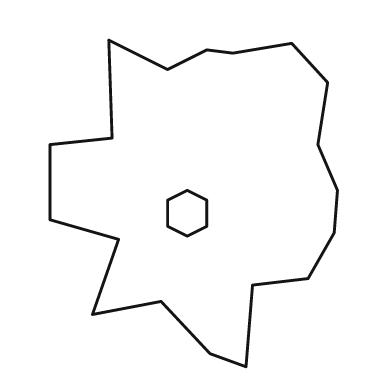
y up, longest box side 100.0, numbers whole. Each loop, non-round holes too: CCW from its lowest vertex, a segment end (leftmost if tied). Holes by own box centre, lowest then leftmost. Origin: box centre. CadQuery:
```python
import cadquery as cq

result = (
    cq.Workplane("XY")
    .moveTo(16.0, -50.0)
    .lineTo(18.0, -25.0)
    .lineTo(35.0, -23.0)
    .lineTo(43.0, -9.0)
    .lineTo(44.0, 4.0)
    .lineTo(38.0, 18.0)
    .lineTo(41.0, 37.0)
    .lineTo(30.0, 49.0)
    .lineTo(12.0, 46.0)
    .lineTo(4.0, 47.0)
    .lineTo(-8.0, 41.0)
    .lineTo(-26.0, 50.0)
    .lineTo(-25.0, 20.0)
    .lineTo(-44.0, 18.0)
    .lineTo(-44.0, -5.0)
    .lineTo(-23.0, -11.0)
    .lineTo(-31.0, -34.0)
    .lineTo(-10.0, -30.0)
    .lineTo(5.0, -46.0)
    .close()
    .moveTo(-2.0, -10.0)
    .lineTo(4.0, -7.0)
    .lineTo(4.0, 1.0)
    .lineTo(-2.0, 4.0)
    .lineTo(-8.0, 1.0)
    .lineTo(-8.0, -7.0)
    .close()
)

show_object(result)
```